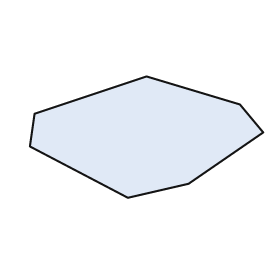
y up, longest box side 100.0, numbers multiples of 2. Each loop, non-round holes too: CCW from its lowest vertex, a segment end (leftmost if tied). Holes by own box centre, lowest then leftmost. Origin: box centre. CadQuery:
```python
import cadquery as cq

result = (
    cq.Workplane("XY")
    .moveTo(-8.0, -26.0)
    .lineTo(18.0, -20.0)
    .lineTo(50.0, 2.0)
    .lineTo(40.0, 14.0)
    .lineTo(0.0, 26.0)
    .lineTo(-48.0, 10.0)
    .lineTo(-50.0, -4.0)
    .close()
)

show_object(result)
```